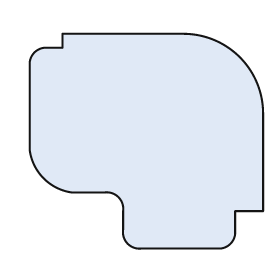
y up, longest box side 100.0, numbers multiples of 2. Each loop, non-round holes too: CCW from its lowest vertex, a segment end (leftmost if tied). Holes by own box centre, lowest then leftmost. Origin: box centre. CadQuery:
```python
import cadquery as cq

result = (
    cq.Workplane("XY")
    .moveTo(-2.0, -46.0)
    .lineTo(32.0, -46.0)
    .threePointArc((36.0, -44.0), (38.0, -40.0))
    .lineTo(38.0, -30.0)
    .lineTo(50.0, -30.0)
    .lineTo(50.0, 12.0)
    .threePointArc((40.0, 36.0), (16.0, 46.0))
    .lineTo(-36.0, 46.0)
    .lineTo(-36.0, 40.0)
    .lineTo(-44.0, 40.0)
    .threePointArc((-48.0, 38.0), (-50.0, 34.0))
    .lineTo(-50.0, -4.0)
    .threePointArc((-44.0, -16.0), (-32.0, -22.0))
    .lineTo(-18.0, -22.0)
    .threePointArc((-12.0, -24.0), (-10.0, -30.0))
    .lineTo(-10.0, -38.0)
    .threePointArc((-8.0, -44.0), (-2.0, -46.0))
    .close()
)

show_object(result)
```